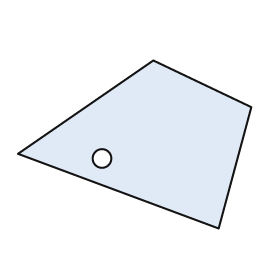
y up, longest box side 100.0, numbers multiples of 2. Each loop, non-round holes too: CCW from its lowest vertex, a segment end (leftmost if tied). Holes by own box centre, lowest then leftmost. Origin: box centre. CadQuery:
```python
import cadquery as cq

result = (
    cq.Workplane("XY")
    .moveTo(36.0, -36.0)
    .lineTo(50.0, 16.0)
    .lineTo(8.0, 36.0)
    .lineTo(-50.0, -4.0)
    .close()
    .moveTo(-14.0, -6.0)
    .circle(4.0)
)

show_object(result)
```